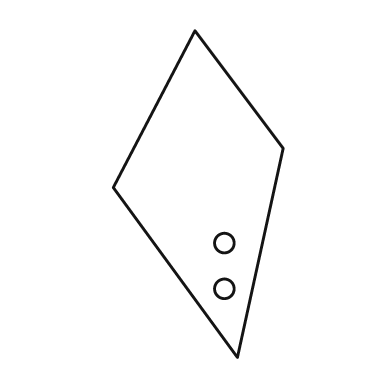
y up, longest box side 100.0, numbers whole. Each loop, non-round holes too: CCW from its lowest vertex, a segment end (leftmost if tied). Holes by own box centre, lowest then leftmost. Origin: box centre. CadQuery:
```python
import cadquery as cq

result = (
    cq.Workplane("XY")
    .moveTo(12.0, -50.0)
    .lineTo(26.0, 14.0)
    .lineTo(-1.0, 50.0)
    .lineTo(-26.0, 2.0)
    .close()
    .moveTo(8.0, -29.0)
    .circle(3.0)
    .moveTo(8.0, -15.0)
    .circle(3.0)
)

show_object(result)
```